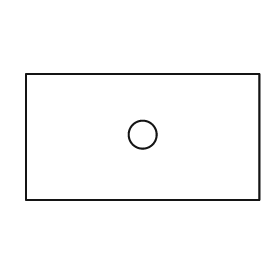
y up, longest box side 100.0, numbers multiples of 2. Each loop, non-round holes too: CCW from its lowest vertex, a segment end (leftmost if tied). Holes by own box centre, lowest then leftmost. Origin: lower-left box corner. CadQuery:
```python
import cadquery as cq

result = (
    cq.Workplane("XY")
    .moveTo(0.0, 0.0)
    .lineTo(100.0, 0.0)
    .lineTo(100.0, 54.0)
    .lineTo(0.0, 54.0)
    .close()
    .moveTo(50.0, 28.0)
    .circle(6.0)
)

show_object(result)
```